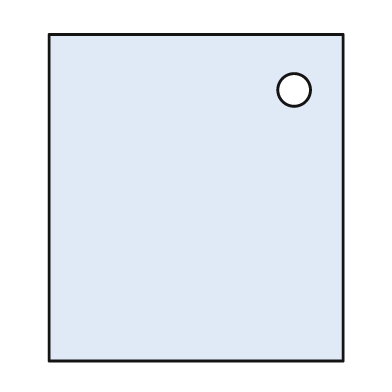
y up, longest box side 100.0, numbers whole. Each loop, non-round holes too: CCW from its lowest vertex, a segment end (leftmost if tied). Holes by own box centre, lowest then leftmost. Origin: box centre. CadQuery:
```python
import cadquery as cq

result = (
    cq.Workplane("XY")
    .moveTo(-45.0, -50.0)
    .lineTo(45.0, -50.0)
    .lineTo(45.0, 50.0)
    .lineTo(-45.0, 50.0)
    .close()
    .moveTo(30.0, 33.0)
    .circle(5.0)
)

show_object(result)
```